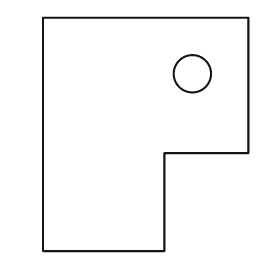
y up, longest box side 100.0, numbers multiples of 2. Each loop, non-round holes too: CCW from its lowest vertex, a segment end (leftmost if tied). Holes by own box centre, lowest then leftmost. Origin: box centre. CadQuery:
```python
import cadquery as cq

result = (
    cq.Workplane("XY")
    .moveTo(-44.0, -50.0)
    .lineTo(8.0, -50.0)
    .lineTo(8.0, -8.0)
    .lineTo(44.0, -8.0)
    .lineTo(44.0, 50.0)
    .lineTo(-44.0, 50.0)
    .close()
    .moveTo(20.0, 26.0)
    .circle(8.0)
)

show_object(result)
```